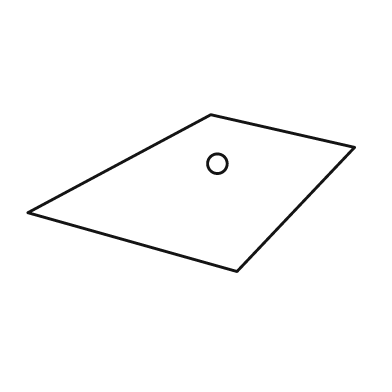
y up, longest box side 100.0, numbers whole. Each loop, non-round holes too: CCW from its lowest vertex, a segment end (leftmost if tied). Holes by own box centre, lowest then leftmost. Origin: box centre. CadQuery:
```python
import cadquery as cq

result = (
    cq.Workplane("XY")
    .moveTo(14.0, -24.0)
    .lineTo(50.0, 14.0)
    .lineTo(6.0, 24.0)
    .lineTo(-50.0, -6.0)
    .close()
    .moveTo(8.0, 9.0)
    .circle(3.0)
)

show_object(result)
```